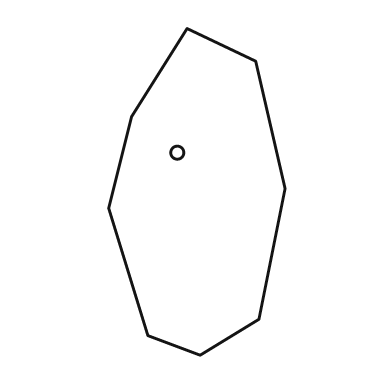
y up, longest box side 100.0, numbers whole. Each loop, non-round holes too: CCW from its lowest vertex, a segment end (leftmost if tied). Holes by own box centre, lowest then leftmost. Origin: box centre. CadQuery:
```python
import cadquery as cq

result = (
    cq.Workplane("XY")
    .moveTo(1.0, -50.0)
    .lineTo(19.0, -39.0)
    .lineTo(27.0, 1.0)
    .lineTo(18.0, 40.0)
    .lineTo(-3.0, 50.0)
    .lineTo(-20.0, 23.0)
    .lineTo(-27.0, -5.0)
    .lineTo(-15.0, -44.0)
    .close()
    .moveTo(-6.0, 12.0)
    .circle(2.0)
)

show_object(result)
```